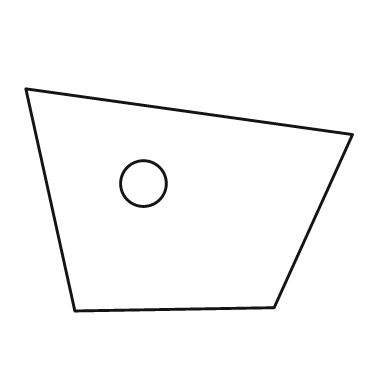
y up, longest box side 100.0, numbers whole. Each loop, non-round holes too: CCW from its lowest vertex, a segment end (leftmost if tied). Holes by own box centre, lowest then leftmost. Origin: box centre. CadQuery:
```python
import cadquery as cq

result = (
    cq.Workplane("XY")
    .moveTo(-35.0, -34.0)
    .lineTo(26.0, -33.0)
    .lineTo(50.0, 20.0)
    .lineTo(-50.0, 34.0)
    .close()
    .moveTo(-14.0, 5.0)
    .circle(7.0)
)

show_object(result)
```